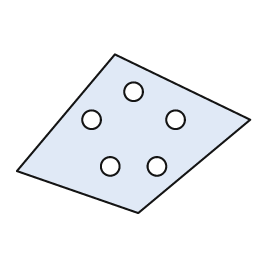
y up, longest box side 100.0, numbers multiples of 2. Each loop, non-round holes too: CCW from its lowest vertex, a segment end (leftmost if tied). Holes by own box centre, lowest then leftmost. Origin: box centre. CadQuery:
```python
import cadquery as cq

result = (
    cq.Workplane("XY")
    .moveTo(2.0, -34.0)
    .lineTo(50.0, 6.0)
    .lineTo(-8.0, 34.0)
    .lineTo(-50.0, -16.0)
    .close()
    .moveTo(-10.0, -14.0)
    .circle(4.0)
    .moveTo(10.0, -14.0)
    .circle(4.0)
    .moveTo(-18.0, 6.0)
    .circle(4.0)
    .moveTo(18.0, 6.0)
    .circle(4.0)
    .moveTo(0.0, 18.0)
    .circle(4.0)
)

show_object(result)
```